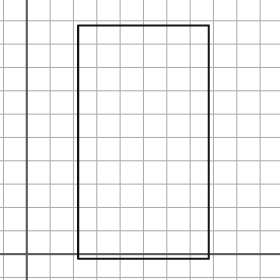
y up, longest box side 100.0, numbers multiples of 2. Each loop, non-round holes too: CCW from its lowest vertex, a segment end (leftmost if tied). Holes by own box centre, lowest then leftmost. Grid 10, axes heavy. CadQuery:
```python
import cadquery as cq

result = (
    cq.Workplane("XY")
    .moveTo(22.0, -2.0)
    .lineTo(78.0, -2.0)
    .lineTo(78.0, 98.0)
    .lineTo(22.0, 98.0)
    .close()
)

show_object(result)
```